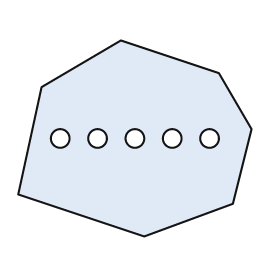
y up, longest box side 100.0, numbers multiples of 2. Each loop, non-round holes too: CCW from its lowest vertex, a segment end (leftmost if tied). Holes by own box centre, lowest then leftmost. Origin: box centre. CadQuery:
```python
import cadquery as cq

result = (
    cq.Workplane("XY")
    .moveTo(4.0, -42.0)
    .lineTo(42.0, -28.0)
    .lineTo(50.0, 4.0)
    .lineTo(36.0, 28.0)
    .lineTo(-6.0, 42.0)
    .lineTo(-40.0, 22.0)
    .lineTo(-50.0, -24.0)
    .close()
    .moveTo(-32.0, 0.0)
    .circle(4.0)
    .moveTo(-16.0, 0.0)
    .circle(4.0)
    .moveTo(0.0, 0.0)
    .circle(4.0)
    .moveTo(16.0, 0.0)
    .circle(4.0)
    .moveTo(32.0, 0.0)
    .circle(4.0)
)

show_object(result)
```